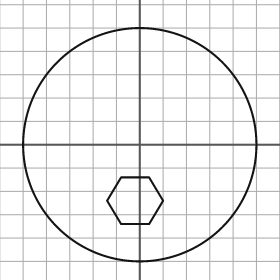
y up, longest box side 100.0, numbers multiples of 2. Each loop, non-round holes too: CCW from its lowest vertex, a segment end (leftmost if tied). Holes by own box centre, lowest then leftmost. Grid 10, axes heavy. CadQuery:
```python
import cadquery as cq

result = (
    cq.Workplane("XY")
    .moveTo(0.0, 0.0)
    .circle(50.0)
    .moveTo(-8.0, -34.0)
    .lineTo(4.0, -34.0)
    .lineTo(10.0, -24.0)
    .lineTo(4.0, -14.0)
    .lineTo(-8.0, -14.0)
    .lineTo(-14.0, -24.0)
    .close()
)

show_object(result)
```